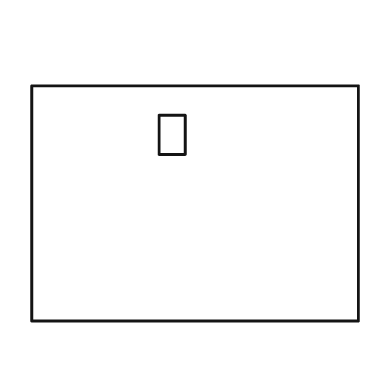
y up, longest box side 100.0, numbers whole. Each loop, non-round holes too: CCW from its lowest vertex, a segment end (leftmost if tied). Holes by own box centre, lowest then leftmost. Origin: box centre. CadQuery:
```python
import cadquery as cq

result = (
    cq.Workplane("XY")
    .moveTo(-50.0, -36.0)
    .lineTo(50.0, -36.0)
    .lineTo(50.0, 36.0)
    .lineTo(-50.0, 36.0)
    .close()
    .moveTo(-11.0, 15.0)
    .lineTo(-3.0, 15.0)
    .lineTo(-3.0, 27.0)
    .lineTo(-11.0, 27.0)
    .close()
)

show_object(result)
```